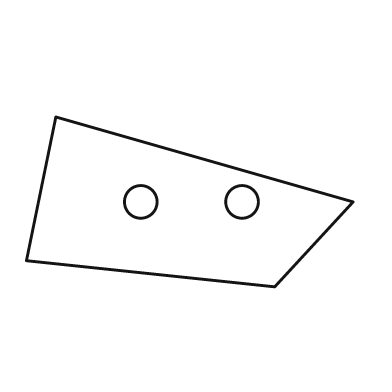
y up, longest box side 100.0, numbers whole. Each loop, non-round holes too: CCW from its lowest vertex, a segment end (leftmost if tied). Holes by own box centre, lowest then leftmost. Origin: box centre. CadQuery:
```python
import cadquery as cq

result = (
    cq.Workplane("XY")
    .moveTo(26.0, -26.0)
    .lineTo(50.0, 0.0)
    .lineTo(-41.0, 26.0)
    .lineTo(-50.0, -18.0)
    .close()
    .moveTo(-15.0, 0.0)
    .circle(5.0)
    .moveTo(16.0, 0.0)
    .circle(5.0)
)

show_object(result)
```